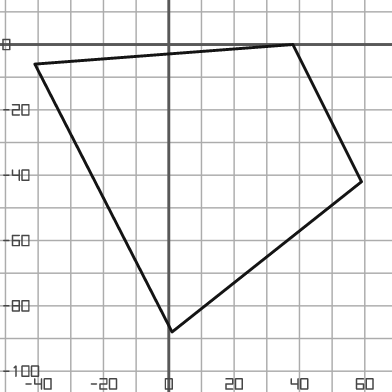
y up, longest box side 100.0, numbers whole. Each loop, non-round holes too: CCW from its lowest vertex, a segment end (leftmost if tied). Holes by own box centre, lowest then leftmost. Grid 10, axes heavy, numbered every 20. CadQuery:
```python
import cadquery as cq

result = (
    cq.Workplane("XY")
    .moveTo(1.0, -88.0)
    .lineTo(59.0, -42.0)
    .lineTo(38.0, 0.0)
    .lineTo(-41.0, -6.0)
    .close()
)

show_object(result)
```